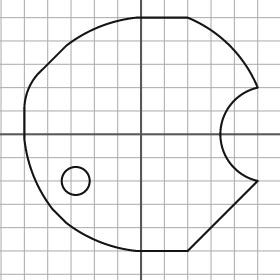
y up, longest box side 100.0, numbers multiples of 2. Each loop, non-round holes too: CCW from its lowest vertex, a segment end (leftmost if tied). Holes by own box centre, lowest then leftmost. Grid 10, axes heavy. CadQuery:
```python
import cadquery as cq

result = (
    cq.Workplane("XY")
    .moveTo(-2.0, -50.0)
    .lineTo(20.0, -50.0)
    .lineTo(50.0, -20.0)
    .threePointArc((34.0, 0.0), (50.0, 20.0))
    .threePointArc((38.0, 38.0), (20.0, 50.0))
    .lineTo(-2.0, 50.0)
    .threePointArc((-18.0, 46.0), (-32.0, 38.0))
    .lineTo(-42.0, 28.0)
    .threePointArc((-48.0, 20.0), (-50.0, 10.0))
    .lineTo(-50.0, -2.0)
    .threePointArc((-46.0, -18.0), (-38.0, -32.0))
    .lineTo(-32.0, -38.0)
    .threePointArc((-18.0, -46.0), (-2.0, -50.0))
    .close()
    .moveTo(-28.0, -20.0)
    .circle(6.0)
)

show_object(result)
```